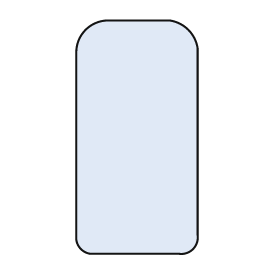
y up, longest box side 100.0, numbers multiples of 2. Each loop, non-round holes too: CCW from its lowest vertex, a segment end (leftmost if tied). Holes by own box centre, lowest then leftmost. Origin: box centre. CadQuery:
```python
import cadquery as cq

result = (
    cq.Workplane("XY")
    .moveTo(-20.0, -50.0)
    .lineTo(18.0, -50.0)
    .threePointArc((24.0, -48.0), (26.0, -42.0))
    .lineTo(26.0, 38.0)
    .threePointArc((22.0, 46.0), (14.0, 50.0))
    .lineTo(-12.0, 50.0)
    .threePointArc((-22.0, 46.0), (-26.0, 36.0))
    .lineTo(-26.0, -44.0)
    .threePointArc((-24.0, -48.0), (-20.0, -50.0))
    .close()
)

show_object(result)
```